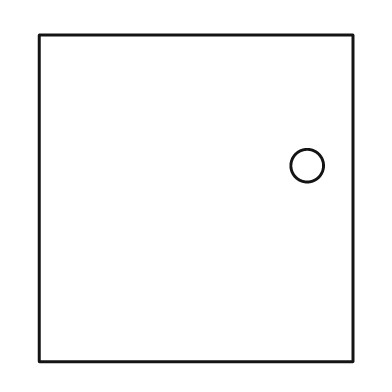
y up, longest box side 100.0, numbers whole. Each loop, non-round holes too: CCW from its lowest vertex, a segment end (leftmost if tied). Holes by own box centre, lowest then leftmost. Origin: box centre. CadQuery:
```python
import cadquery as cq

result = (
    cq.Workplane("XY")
    .moveTo(-48.0, -50.0)
    .lineTo(48.0, -50.0)
    .lineTo(48.0, 50.0)
    .lineTo(-48.0, 50.0)
    .close()
    .moveTo(34.0, 10.0)
    .circle(5.0)
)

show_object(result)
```